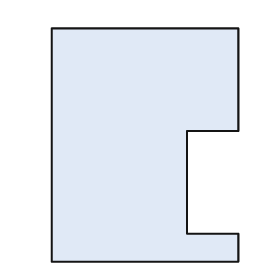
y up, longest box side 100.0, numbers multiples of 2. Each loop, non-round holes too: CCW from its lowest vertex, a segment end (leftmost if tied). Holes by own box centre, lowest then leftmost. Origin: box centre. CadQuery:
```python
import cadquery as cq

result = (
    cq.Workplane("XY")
    .moveTo(-40.0, -50.0)
    .lineTo(40.0, -50.0)
    .lineTo(40.0, -38.0)
    .lineTo(18.0, -38.0)
    .lineTo(18.0, 6.0)
    .lineTo(40.0, 6.0)
    .lineTo(40.0, 50.0)
    .lineTo(-40.0, 50.0)
    .close()
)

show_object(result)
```